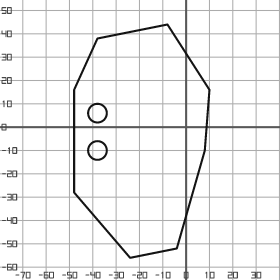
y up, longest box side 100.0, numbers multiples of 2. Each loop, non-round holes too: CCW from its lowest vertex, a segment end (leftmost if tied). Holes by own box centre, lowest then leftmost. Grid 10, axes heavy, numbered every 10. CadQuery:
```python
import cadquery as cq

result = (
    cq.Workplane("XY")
    .moveTo(-24.0, -56.0)
    .lineTo(-4.0, -52.0)
    .lineTo(8.0, -10.0)
    .lineTo(10.0, 16.0)
    .lineTo(-8.0, 44.0)
    .lineTo(-38.0, 38.0)
    .lineTo(-48.0, 16.0)
    .lineTo(-48.0, -28.0)
    .close()
    .moveTo(-38.0, -10.0)
    .circle(4.0)
    .moveTo(-38.0, 6.0)
    .circle(4.0)
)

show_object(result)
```